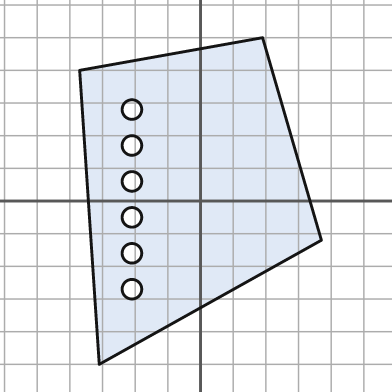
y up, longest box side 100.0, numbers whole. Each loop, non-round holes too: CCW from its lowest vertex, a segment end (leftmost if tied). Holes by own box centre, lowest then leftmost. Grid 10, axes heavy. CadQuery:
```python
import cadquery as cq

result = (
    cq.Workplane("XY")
    .moveTo(-31.0, -50.0)
    .lineTo(37.0, -12.0)
    .lineTo(19.0, 50.0)
    .lineTo(-37.0, 40.0)
    .close()
    .moveTo(-21.0, -27.0)
    .circle(3.0)
    .moveTo(-21.0, -16.0)
    .circle(3.0)
    .moveTo(-21.0, -5.0)
    .circle(3.0)
    .moveTo(-21.0, 6.0)
    .circle(3.0)
    .moveTo(-21.0, 17.0)
    .circle(3.0)
    .moveTo(-21.0, 28.0)
    .circle(3.0)
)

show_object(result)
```